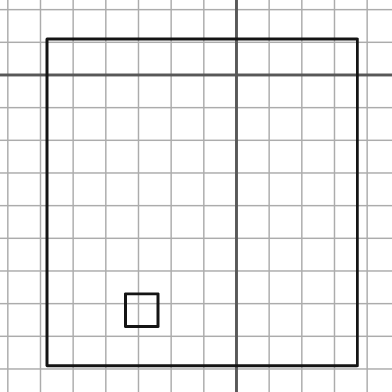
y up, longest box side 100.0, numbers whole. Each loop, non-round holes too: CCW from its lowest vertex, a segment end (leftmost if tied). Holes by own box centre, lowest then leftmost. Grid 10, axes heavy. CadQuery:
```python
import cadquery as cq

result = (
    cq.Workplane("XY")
    .moveTo(-58.0, -89.0)
    .lineTo(37.0, -89.0)
    .lineTo(37.0, 11.0)
    .lineTo(-58.0, 11.0)
    .close()
    .moveTo(-34.0, -77.0)
    .lineTo(-24.0, -77.0)
    .lineTo(-24.0, -67.0)
    .lineTo(-34.0, -67.0)
    .close()
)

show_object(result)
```